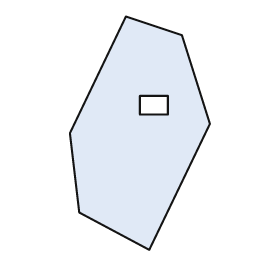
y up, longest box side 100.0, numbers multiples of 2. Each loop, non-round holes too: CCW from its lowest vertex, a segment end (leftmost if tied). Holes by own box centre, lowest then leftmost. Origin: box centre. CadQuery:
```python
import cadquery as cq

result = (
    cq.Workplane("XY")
    .moveTo(4.0, -50.0)
    .lineTo(30.0, 4.0)
    .lineTo(18.0, 42.0)
    .lineTo(-6.0, 50.0)
    .lineTo(-30.0, 0.0)
    .lineTo(-26.0, -34.0)
    .close()
    .moveTo(0.0, 8.0)
    .lineTo(12.0, 8.0)
    .lineTo(12.0, 16.0)
    .lineTo(0.0, 16.0)
    .close()
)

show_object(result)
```